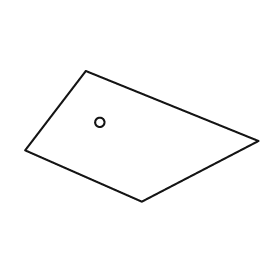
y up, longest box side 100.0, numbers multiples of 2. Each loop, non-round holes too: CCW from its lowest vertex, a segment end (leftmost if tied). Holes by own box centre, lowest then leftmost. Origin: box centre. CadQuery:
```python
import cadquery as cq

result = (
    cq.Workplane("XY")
    .moveTo(0.0, -28.0)
    .lineTo(50.0, -2.0)
    .lineTo(-24.0, 28.0)
    .lineTo(-50.0, -6.0)
    .close()
    .moveTo(-18.0, 6.0)
    .circle(2.0)
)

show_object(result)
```